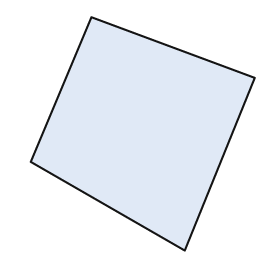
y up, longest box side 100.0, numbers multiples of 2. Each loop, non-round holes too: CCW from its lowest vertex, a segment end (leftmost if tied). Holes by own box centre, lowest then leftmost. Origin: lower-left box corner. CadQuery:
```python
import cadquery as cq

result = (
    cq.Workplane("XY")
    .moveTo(66.0, 0.0)
    .lineTo(96.0, 74.0)
    .lineTo(26.0, 100.0)
    .lineTo(0.0, 38.0)
    .close()
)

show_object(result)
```